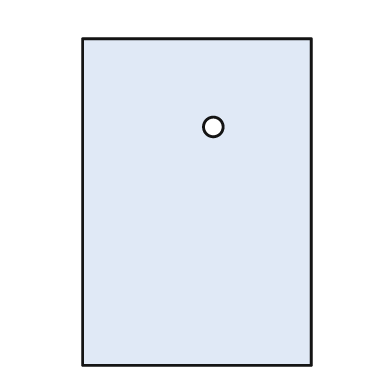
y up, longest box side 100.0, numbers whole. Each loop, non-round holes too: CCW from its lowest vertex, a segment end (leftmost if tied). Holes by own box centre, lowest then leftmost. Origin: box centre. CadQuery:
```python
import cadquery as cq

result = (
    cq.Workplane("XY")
    .moveTo(-35.0, -50.0)
    .lineTo(35.0, -50.0)
    .lineTo(35.0, 50.0)
    .lineTo(-35.0, 50.0)
    .close()
    .moveTo(5.0, 23.0)
    .circle(3.0)
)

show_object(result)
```